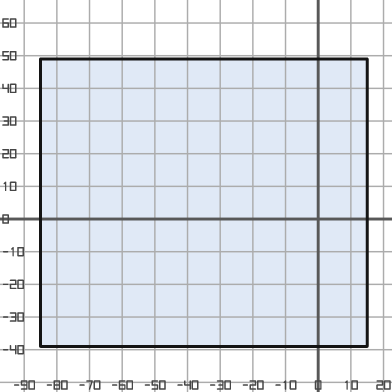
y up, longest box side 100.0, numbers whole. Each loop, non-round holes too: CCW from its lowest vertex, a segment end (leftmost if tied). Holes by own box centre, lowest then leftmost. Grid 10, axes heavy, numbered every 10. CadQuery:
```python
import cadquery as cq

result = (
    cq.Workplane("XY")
    .moveTo(-85.0, -39.0)
    .lineTo(15.0, -39.0)
    .lineTo(15.0, 49.0)
    .lineTo(-85.0, 49.0)
    .close()
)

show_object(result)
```